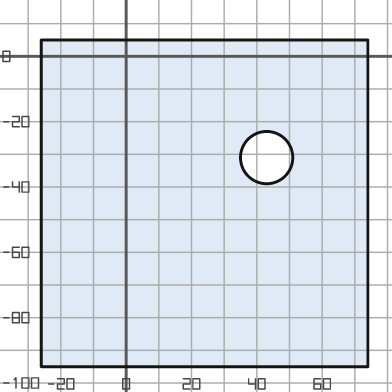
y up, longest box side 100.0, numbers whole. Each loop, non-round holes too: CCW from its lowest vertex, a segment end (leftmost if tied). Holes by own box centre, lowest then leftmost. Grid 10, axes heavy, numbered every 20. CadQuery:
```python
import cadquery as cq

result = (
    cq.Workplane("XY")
    .moveTo(-26.0, -95.0)
    .lineTo(74.0, -95.0)
    .lineTo(74.0, 5.0)
    .lineTo(-26.0, 5.0)
    .close()
    .moveTo(43.0, -31.0)
    .circle(8.0)
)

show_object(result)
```